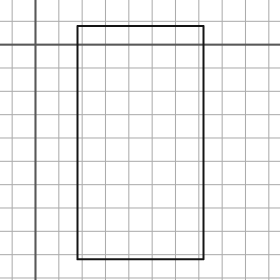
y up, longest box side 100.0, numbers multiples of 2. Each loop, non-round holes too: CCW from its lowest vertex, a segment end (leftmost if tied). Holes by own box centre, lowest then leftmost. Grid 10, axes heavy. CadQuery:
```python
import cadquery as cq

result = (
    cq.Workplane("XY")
    .moveTo(18.0, -92.0)
    .lineTo(72.0, -92.0)
    .lineTo(72.0, 8.0)
    .lineTo(18.0, 8.0)
    .close()
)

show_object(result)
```